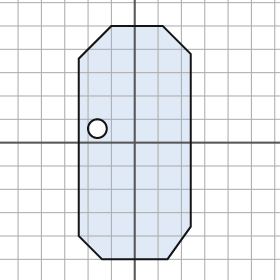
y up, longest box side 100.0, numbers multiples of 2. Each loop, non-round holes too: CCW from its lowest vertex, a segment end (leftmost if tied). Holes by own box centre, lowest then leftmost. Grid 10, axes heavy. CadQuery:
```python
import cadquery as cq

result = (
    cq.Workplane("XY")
    .moveTo(-14.0, -50.0)
    .lineTo(14.0, -50.0)
    .lineTo(24.0, -36.0)
    .lineTo(24.0, 38.0)
    .lineTo(12.0, 50.0)
    .lineTo(-10.0, 50.0)
    .lineTo(-24.0, 36.0)
    .lineTo(-24.0, -40.0)
    .close()
    .moveTo(-16.0, 6.0)
    .circle(4.0)
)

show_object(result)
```